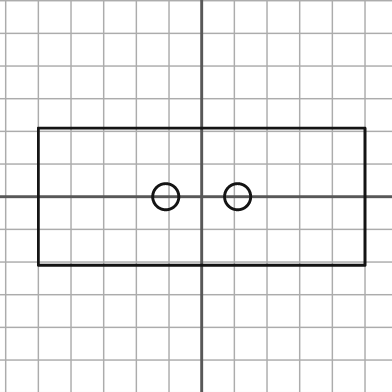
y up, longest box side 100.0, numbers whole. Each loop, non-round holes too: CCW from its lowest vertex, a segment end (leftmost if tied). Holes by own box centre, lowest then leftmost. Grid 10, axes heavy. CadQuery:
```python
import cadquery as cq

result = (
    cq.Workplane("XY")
    .moveTo(-50.0, -21.0)
    .lineTo(50.0, -21.0)
    .lineTo(50.0, 21.0)
    .lineTo(-50.0, 21.0)
    .close()
    .moveTo(-11.0, 0.0)
    .circle(4.0)
    .moveTo(11.0, 0.0)
    .circle(4.0)
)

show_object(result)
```